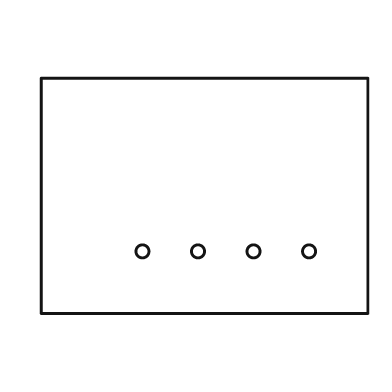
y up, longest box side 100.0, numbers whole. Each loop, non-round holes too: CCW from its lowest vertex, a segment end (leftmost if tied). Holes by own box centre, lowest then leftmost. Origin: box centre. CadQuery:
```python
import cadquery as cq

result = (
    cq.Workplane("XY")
    .moveTo(-50.0, -36.0)
    .lineTo(50.0, -36.0)
    .lineTo(50.0, 36.0)
    .lineTo(-50.0, 36.0)
    .close()
    .moveTo(-19.0, -17.0)
    .circle(2.0)
    .moveTo(-2.0, -17.0)
    .circle(2.0)
    .moveTo(15.0, -17.0)
    .circle(2.0)
    .moveTo(32.0, -17.0)
    .circle(2.0)
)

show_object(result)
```